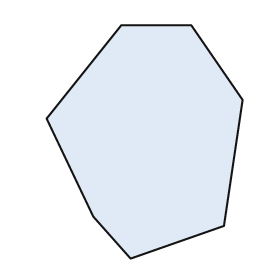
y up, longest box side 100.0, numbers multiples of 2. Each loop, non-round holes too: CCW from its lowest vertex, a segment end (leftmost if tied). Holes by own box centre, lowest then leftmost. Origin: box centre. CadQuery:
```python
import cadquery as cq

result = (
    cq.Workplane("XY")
    .moveTo(-6.0, -50.0)
    .lineTo(34.0, -36.0)
    .lineTo(42.0, 18.0)
    .lineTo(20.0, 50.0)
    .lineTo(-10.0, 50.0)
    .lineTo(-42.0, 10.0)
    .lineTo(-22.0, -32.0)
    .close()
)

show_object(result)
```